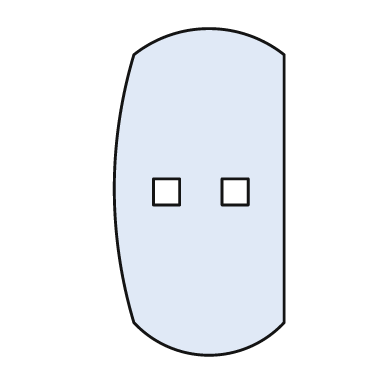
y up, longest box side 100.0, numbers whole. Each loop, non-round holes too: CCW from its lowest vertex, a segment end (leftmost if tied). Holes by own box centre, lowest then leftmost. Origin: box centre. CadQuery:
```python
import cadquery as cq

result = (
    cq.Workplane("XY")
    .moveTo(-20.0, -40.0)
    .threePointArc((3.0, -50.0), (26.0, -40.0))
    .lineTo(26.0, 42.0)
    .threePointArc((3.0, 50.0), (-20.0, 42.0))
    .threePointArc((-26.0, 1.0), (-20.0, -40.0))
    .close()
    .moveTo(-14.0, -4.0)
    .lineTo(-6.0, -4.0)
    .lineTo(-6.0, 4.0)
    .lineTo(-14.0, 4.0)
    .close()
    .moveTo(7.0, -4.0)
    .lineTo(15.0, -4.0)
    .lineTo(15.0, 4.0)
    .lineTo(7.0, 4.0)
    .close()
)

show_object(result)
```